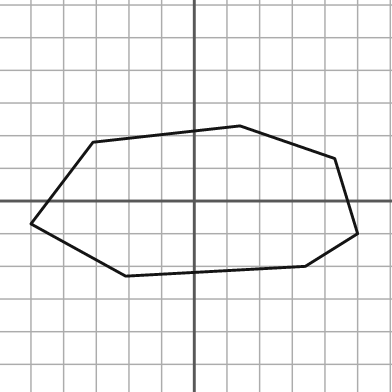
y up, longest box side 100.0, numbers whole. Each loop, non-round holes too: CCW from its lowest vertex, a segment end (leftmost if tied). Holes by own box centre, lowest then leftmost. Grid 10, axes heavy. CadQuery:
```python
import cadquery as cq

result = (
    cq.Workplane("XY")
    .moveTo(-21.0, -23.0)
    .lineTo(34.0, -20.0)
    .lineTo(50.0, -10.0)
    .lineTo(43.0, 13.0)
    .lineTo(14.0, 23.0)
    .lineTo(-31.0, 18.0)
    .lineTo(-50.0, -7.0)
    .close()
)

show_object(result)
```